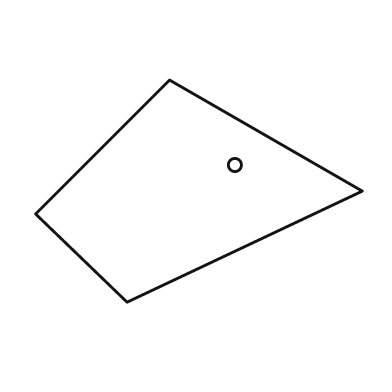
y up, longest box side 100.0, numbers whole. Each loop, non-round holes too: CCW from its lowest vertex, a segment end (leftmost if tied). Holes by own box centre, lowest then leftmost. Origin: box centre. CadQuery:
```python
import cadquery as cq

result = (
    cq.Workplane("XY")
    .moveTo(-22.0, -34.0)
    .lineTo(50.0, 0.0)
    .lineTo(-9.0, 34.0)
    .lineTo(-50.0, -7.0)
    .close()
    .moveTo(11.0, 8.0)
    .circle(2.0)
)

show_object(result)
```